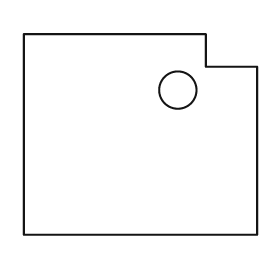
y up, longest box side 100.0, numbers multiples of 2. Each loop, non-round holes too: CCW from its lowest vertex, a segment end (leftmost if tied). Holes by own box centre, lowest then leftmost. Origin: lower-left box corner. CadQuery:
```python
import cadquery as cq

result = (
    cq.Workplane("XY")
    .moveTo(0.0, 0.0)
    .lineTo(100.0, 0.0)
    .lineTo(100.0, 72.0)
    .lineTo(78.0, 72.0)
    .lineTo(78.0, 86.0)
    .lineTo(0.0, 86.0)
    .close()
    .moveTo(66.0, 62.0)
    .circle(8.0)
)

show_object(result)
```